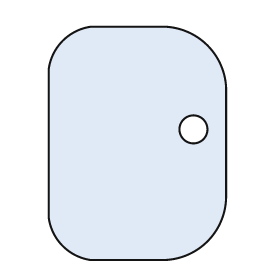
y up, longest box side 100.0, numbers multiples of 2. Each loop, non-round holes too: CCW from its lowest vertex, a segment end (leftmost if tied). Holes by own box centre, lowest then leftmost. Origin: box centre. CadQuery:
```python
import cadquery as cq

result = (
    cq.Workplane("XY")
    .moveTo(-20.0, -50.0)
    .lineTo(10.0, -50.0)
    .threePointArc((30.0, -42.0), (38.0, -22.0))
    .lineTo(38.0, 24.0)
    .threePointArc((30.0, 42.0), (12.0, 50.0))
    .lineTo(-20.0, 50.0)
    .threePointArc((-32.0, 44.0), (-38.0, 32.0))
    .lineTo(-38.0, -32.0)
    .threePointArc((-32.0, -44.0), (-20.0, -50.0))
    .close()
    .moveTo(24.0, 6.0)
    .circle(6.0)
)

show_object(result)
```